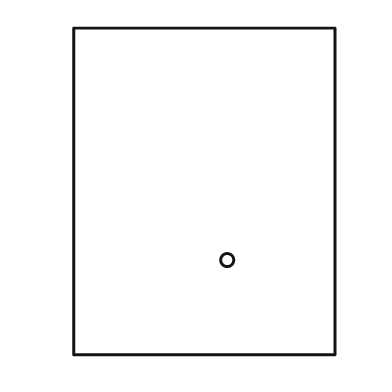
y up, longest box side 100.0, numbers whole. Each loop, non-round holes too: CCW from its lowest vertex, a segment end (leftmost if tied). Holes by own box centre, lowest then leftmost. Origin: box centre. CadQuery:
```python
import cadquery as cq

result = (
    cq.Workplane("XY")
    .moveTo(-40.0, -50.0)
    .lineTo(40.0, -50.0)
    .lineTo(40.0, 50.0)
    .lineTo(-40.0, 50.0)
    .close()
    .moveTo(7.0, -21.0)
    .circle(2.0)
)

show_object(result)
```